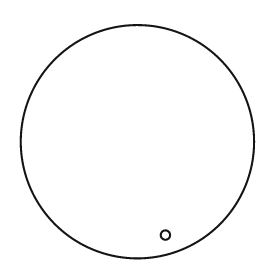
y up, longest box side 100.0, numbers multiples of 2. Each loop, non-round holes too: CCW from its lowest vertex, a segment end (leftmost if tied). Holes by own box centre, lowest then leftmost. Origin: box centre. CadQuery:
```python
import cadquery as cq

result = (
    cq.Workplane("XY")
    .moveTo(0.0, 0.0)
    .circle(50.0)
    .moveTo(12.0, -40.0)
    .circle(2.0)
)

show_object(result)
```